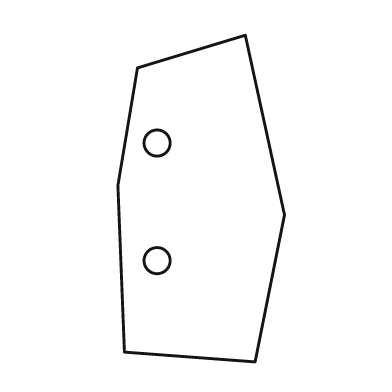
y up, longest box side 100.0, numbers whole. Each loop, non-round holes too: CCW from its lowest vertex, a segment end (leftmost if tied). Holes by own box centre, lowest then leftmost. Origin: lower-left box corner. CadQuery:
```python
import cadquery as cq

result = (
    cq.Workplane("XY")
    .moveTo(42.0, 0.0)
    .lineTo(51.0, 45.0)
    .lineTo(39.0, 100.0)
    .lineTo(6.0, 90.0)
    .lineTo(0.0, 54.0)
    .lineTo(2.0, 3.0)
    .close()
    .moveTo(12.0, 31.0)
    .circle(4.0)
    .moveTo(12.0, 67.0)
    .circle(4.0)
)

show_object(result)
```